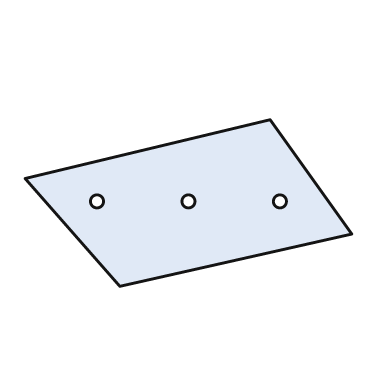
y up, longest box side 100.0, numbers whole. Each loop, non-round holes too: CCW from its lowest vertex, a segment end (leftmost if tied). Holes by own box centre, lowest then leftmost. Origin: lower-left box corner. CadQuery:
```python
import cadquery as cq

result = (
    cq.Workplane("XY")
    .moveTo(29.0, 0.0)
    .lineTo(100.0, 16.0)
    .lineTo(75.0, 51.0)
    .lineTo(0.0, 33.0)
    .close()
    .moveTo(22.0, 26.0)
    .circle(2.0)
    .moveTo(50.0, 26.0)
    .circle(2.0)
    .moveTo(78.0, 26.0)
    .circle(2.0)
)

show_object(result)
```